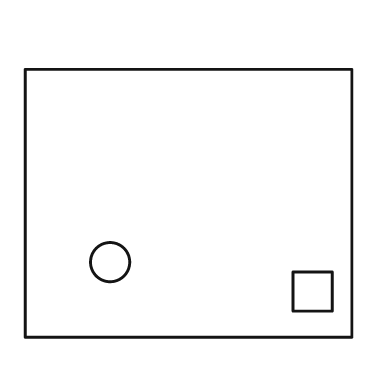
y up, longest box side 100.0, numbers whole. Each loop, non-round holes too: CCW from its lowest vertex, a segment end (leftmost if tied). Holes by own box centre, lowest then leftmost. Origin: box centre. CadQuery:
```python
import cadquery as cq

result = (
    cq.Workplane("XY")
    .moveTo(-50.0, -41.0)
    .lineTo(50.0, -41.0)
    .lineTo(50.0, 41.0)
    .lineTo(-50.0, 41.0)
    .close()
    .moveTo(32.0, -33.0)
    .lineTo(44.0, -33.0)
    .lineTo(44.0, -21.0)
    .lineTo(32.0, -21.0)
    .close()
    .moveTo(-24.0, -18.0)
    .circle(6.0)
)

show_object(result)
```